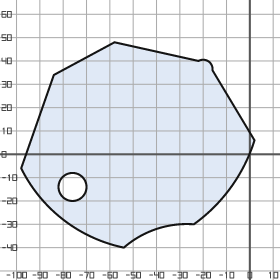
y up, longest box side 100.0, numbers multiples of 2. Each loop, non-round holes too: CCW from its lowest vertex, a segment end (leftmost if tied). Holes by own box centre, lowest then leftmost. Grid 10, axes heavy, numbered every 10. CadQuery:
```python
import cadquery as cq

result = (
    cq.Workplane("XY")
    .moveTo(-54.0, -40.0)
    .threePointArc((-40.0, -32.0), (-24.0, -30.0))
    .threePointArc((-8.0, -14.0), (2.0, 6.0))
    .lineTo(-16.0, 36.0)
    .threePointArc((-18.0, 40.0), (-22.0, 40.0))
    .lineTo(-58.0, 48.0)
    .lineTo(-84.0, 34.0)
    .lineTo(-98.0, -6.0)
    .threePointArc((-80.0, -28.0), (-54.0, -40.0))
    .close()
    .moveTo(-76.0, -14.0)
    .circle(6.0)
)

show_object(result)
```